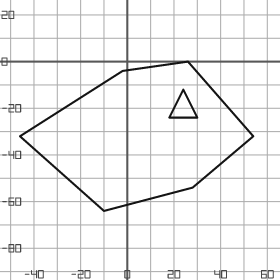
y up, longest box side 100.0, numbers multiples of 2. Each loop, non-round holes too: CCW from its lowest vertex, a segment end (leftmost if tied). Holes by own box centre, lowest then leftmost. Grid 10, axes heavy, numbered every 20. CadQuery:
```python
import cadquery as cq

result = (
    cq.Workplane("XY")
    .moveTo(-10.0, -64.0)
    .lineTo(28.0, -54.0)
    .lineTo(54.0, -32.0)
    .lineTo(26.0, 0.0)
    .lineTo(-2.0, -4.0)
    .lineTo(-46.0, -32.0)
    .close()
    .moveTo(18.0, -24.0)
    .lineTo(30.0, -24.0)
    .lineTo(24.0, -12.0)
    .close()
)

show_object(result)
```